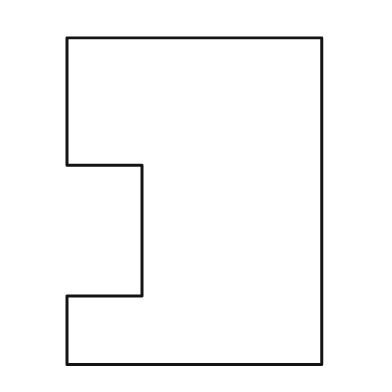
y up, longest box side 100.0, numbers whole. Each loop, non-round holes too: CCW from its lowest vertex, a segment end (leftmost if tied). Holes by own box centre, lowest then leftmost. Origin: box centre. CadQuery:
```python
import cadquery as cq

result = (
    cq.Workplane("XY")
    .moveTo(-39.0, -50.0)
    .lineTo(39.0, -50.0)
    .lineTo(39.0, 50.0)
    .lineTo(-39.0, 50.0)
    .lineTo(-39.0, 11.0)
    .lineTo(-16.0, 11.0)
    .lineTo(-16.0, -29.0)
    .lineTo(-39.0, -29.0)
    .close()
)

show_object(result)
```